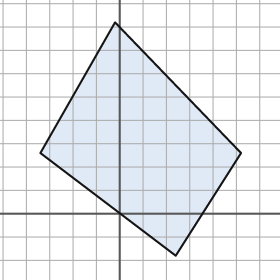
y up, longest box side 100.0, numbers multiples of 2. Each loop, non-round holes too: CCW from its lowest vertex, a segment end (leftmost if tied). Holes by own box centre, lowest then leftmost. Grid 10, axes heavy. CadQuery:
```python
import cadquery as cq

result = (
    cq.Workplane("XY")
    .moveTo(24.0, -18.0)
    .lineTo(52.0, 26.0)
    .lineTo(-2.0, 82.0)
    .lineTo(-34.0, 26.0)
    .close()
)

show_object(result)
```